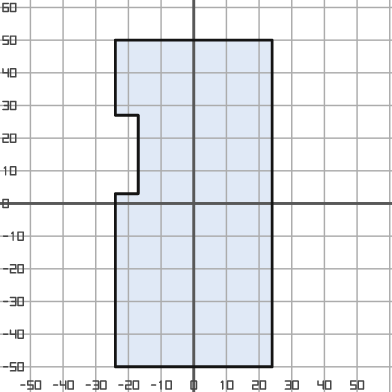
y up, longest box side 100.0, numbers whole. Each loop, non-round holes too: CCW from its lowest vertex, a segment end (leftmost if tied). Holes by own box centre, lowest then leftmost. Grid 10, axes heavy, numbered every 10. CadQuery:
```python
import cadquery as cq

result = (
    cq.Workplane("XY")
    .moveTo(-24.0, -50.0)
    .lineTo(24.0, -50.0)
    .lineTo(24.0, 50.0)
    .lineTo(-24.0, 50.0)
    .lineTo(-24.0, 27.0)
    .lineTo(-17.0, 27.0)
    .lineTo(-17.0, 3.0)
    .lineTo(-24.0, 3.0)
    .close()
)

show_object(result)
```